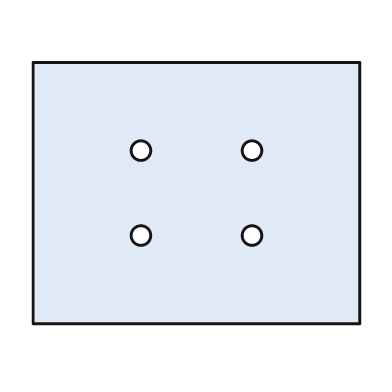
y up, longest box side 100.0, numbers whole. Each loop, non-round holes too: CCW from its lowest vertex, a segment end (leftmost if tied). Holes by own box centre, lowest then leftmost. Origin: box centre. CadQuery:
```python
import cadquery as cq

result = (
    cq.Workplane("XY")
    .moveTo(-50.0, -40.0)
    .lineTo(50.0, -40.0)
    .lineTo(50.0, 40.0)
    .lineTo(-50.0, 40.0)
    .close()
    .moveTo(-17.0, -13.0)
    .circle(3.0)
    .moveTo(17.0, -13.0)
    .circle(3.0)
    .moveTo(-17.0, 13.0)
    .circle(3.0)
    .moveTo(17.0, 13.0)
    .circle(3.0)
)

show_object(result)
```